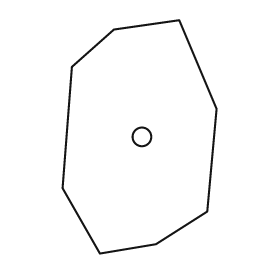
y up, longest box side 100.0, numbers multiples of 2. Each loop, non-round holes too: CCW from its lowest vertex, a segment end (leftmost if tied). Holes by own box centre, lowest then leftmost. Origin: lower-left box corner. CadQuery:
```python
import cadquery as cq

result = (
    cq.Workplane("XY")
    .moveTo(16.0, 0.0)
    .lineTo(40.0, 4.0)
    .lineTo(62.0, 18.0)
    .lineTo(66.0, 62.0)
    .lineTo(50.0, 100.0)
    .lineTo(22.0, 96.0)
    .lineTo(4.0, 80.0)
    .lineTo(0.0, 28.0)
    .close()
    .moveTo(34.0, 50.0)
    .circle(4.0)
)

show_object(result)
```